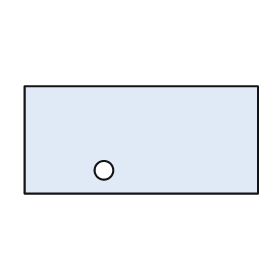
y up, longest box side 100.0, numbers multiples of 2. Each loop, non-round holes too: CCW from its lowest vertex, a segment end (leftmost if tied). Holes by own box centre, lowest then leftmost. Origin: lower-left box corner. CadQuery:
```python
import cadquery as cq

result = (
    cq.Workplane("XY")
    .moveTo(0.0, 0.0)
    .lineTo(100.0, 0.0)
    .lineTo(100.0, 46.0)
    .lineTo(0.0, 46.0)
    .close()
    .moveTo(34.0, 10.0)
    .circle(4.0)
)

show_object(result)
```